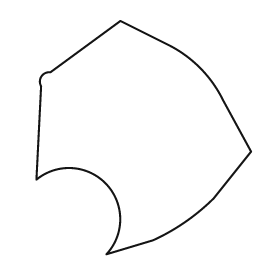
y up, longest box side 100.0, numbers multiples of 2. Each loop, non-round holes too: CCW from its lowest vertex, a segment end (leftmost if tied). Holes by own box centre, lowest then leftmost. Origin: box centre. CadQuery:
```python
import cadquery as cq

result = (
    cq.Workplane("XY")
    .moveTo(-16.0, -50.0)
    .lineTo(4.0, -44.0)
    .threePointArc((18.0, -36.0), (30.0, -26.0))
    .lineTo(46.0, -6.0)
    .lineTo(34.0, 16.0)
    .threePointArc((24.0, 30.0), (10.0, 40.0))
    .lineTo(-10.0, 50.0)
    .lineTo(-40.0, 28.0)
    .threePointArc((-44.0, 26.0), (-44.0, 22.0))
    .lineTo(-46.0, -18.0)
    .threePointArc((-16.0, -20.0), (-16.0, -50.0))
    .close()
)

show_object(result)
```